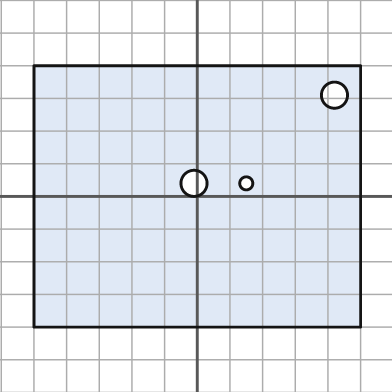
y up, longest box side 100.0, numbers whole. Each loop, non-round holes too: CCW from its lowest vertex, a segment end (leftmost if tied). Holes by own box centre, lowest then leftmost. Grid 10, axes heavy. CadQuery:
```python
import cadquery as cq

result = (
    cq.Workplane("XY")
    .moveTo(-50.0, -40.0)
    .lineTo(50.0, -40.0)
    .lineTo(50.0, 40.0)
    .lineTo(-50.0, 40.0)
    .close()
    .moveTo(-1.0, 4.0)
    .circle(4.0)
    .moveTo(15.0, 4.0)
    .circle(2.0)
    .moveTo(42.0, 31.0)
    .circle(4.0)
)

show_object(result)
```